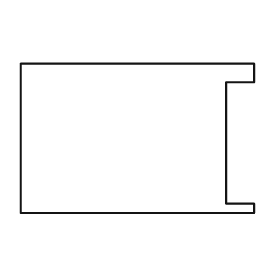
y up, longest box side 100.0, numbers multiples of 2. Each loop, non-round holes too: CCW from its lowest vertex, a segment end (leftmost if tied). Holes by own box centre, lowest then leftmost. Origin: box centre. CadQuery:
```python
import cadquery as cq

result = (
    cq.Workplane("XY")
    .moveTo(-50.0, -32.0)
    .lineTo(50.0, -32.0)
    .lineTo(50.0, -28.0)
    .lineTo(38.0, -28.0)
    .lineTo(38.0, 24.0)
    .lineTo(50.0, 24.0)
    .lineTo(50.0, 32.0)
    .lineTo(-50.0, 32.0)
    .close()
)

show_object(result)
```